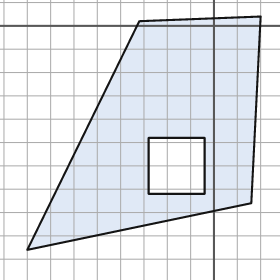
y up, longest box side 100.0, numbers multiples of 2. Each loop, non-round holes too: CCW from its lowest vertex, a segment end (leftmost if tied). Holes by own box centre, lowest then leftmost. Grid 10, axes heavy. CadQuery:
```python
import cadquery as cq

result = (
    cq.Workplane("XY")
    .moveTo(-80.0, -96.0)
    .lineTo(16.0, -76.0)
    .lineTo(20.0, 4.0)
    .lineTo(-32.0, 2.0)
    .close()
    .moveTo(-28.0, -72.0)
    .lineTo(-4.0, -72.0)
    .lineTo(-4.0, -48.0)
    .lineTo(-28.0, -48.0)
    .close()
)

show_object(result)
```